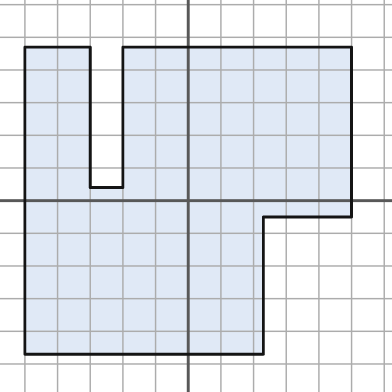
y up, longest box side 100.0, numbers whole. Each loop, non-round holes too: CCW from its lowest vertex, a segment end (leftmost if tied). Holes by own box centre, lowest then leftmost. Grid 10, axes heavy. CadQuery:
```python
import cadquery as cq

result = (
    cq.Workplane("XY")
    .moveTo(-50.0, -47.0)
    .lineTo(23.0, -47.0)
    .lineTo(23.0, -5.0)
    .lineTo(50.0, -5.0)
    .lineTo(50.0, 47.0)
    .lineTo(-20.0, 47.0)
    .lineTo(-20.0, 4.0)
    .lineTo(-30.0, 4.0)
    .lineTo(-30.0, 47.0)
    .lineTo(-50.0, 47.0)
    .close()
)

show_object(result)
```